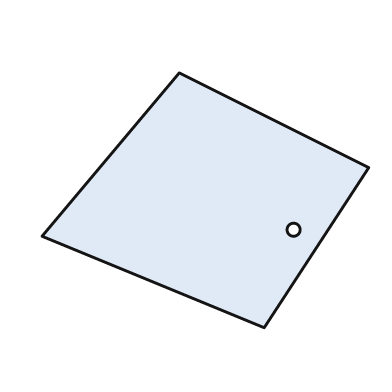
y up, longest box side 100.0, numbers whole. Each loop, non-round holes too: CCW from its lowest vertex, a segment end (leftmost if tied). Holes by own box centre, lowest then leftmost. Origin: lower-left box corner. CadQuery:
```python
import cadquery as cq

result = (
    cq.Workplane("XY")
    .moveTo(68.0, 0.0)
    .lineTo(100.0, 49.0)
    .lineTo(42.0, 78.0)
    .lineTo(0.0, 28.0)
    .close()
    .moveTo(77.0, 30.0)
    .circle(2.0)
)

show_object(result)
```